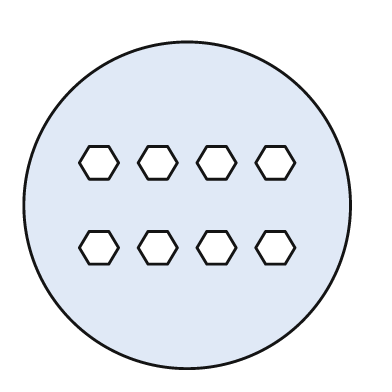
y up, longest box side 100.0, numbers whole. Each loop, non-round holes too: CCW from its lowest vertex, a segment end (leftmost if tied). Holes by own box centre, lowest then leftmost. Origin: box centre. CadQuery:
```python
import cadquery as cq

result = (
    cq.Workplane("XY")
    .moveTo(0.0, 0.0)
    .circle(50.0)
    .moveTo(-30.0, -18.0)
    .lineTo(-24.0, -18.0)
    .lineTo(-21.0, -13.0)
    .lineTo(-24.0, -8.0)
    .lineTo(-30.0, -8.0)
    .lineTo(-33.0, -13.0)
    .close()
    .moveTo(-12.0, -18.0)
    .lineTo(-6.0, -18.0)
    .lineTo(-3.0, -13.0)
    .lineTo(-6.0, -8.0)
    .lineTo(-12.0, -8.0)
    .lineTo(-15.0, -13.0)
    .close()
    .moveTo(6.0, -18.0)
    .lineTo(12.0, -18.0)
    .lineTo(15.0, -13.0)
    .lineTo(12.0, -8.0)
    .lineTo(6.0, -8.0)
    .lineTo(3.0, -13.0)
    .close()
    .moveTo(24.0, -18.0)
    .lineTo(30.0, -18.0)
    .lineTo(33.0, -13.0)
    .lineTo(30.0, -8.0)
    .lineTo(24.0, -8.0)
    .lineTo(21.0, -13.0)
    .close()
    .moveTo(-30.0, 8.0)
    .lineTo(-24.0, 8.0)
    .lineTo(-21.0, 13.0)
    .lineTo(-24.0, 18.0)
    .lineTo(-30.0, 18.0)
    .lineTo(-33.0, 13.0)
    .close()
    .moveTo(-12.0, 8.0)
    .lineTo(-6.0, 8.0)
    .lineTo(-3.0, 13.0)
    .lineTo(-6.0, 18.0)
    .lineTo(-12.0, 18.0)
    .lineTo(-15.0, 13.0)
    .close()
    .moveTo(6.0, 8.0)
    .lineTo(12.0, 8.0)
    .lineTo(15.0, 13.0)
    .lineTo(12.0, 18.0)
    .lineTo(6.0, 18.0)
    .lineTo(3.0, 13.0)
    .close()
    .moveTo(24.0, 8.0)
    .lineTo(30.0, 8.0)
    .lineTo(33.0, 13.0)
    .lineTo(30.0, 18.0)
    .lineTo(24.0, 18.0)
    .lineTo(21.0, 13.0)
    .close()
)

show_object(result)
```